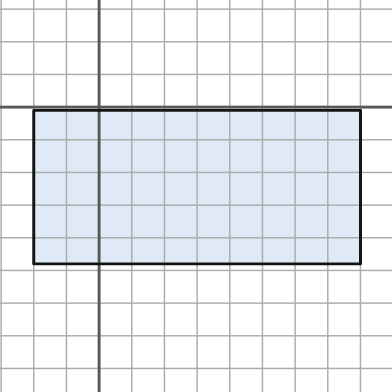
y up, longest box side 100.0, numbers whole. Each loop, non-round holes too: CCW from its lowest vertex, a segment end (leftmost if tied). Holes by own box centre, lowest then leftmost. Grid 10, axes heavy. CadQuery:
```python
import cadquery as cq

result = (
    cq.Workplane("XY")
    .moveTo(-20.0, -48.0)
    .lineTo(80.0, -48.0)
    .lineTo(80.0, -1.0)
    .lineTo(-20.0, -1.0)
    .close()
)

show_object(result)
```